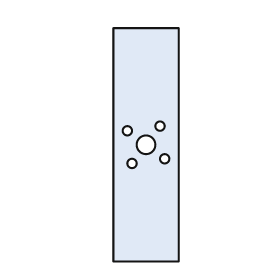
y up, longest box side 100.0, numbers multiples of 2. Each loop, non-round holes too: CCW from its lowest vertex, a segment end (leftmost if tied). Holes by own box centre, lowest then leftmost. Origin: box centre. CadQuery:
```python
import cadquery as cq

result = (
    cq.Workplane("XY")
    .moveTo(-14.0, -50.0)
    .lineTo(14.0, -50.0)
    .lineTo(14.0, 50.0)
    .lineTo(-14.0, 50.0)
    .close()
    .moveTo(-6.0, -8.0)
    .circle(2.0)
    .moveTo(8.0, -6.0)
    .circle(2.0)
    .moveTo(0.0, 0.0)
    .circle(4.0)
    .moveTo(-8.0, 6.0)
    .circle(2.0)
    .moveTo(6.0, 8.0)
    .circle(2.0)
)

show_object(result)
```